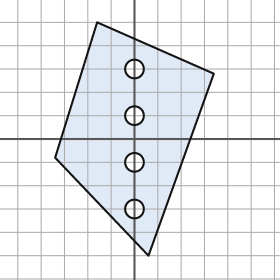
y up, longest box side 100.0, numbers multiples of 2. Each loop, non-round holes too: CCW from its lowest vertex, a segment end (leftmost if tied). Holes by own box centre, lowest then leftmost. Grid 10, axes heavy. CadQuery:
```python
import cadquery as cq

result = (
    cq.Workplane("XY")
    .moveTo(6.0, -50.0)
    .lineTo(34.0, 28.0)
    .lineTo(-16.0, 50.0)
    .lineTo(-34.0, -8.0)
    .close()
    .moveTo(0.0, -30.0)
    .circle(4.0)
    .moveTo(0.0, -10.0)
    .circle(4.0)
    .moveTo(0.0, 10.0)
    .circle(4.0)
    .moveTo(0.0, 30.0)
    .circle(4.0)
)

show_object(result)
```